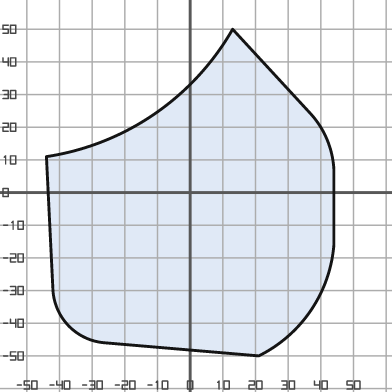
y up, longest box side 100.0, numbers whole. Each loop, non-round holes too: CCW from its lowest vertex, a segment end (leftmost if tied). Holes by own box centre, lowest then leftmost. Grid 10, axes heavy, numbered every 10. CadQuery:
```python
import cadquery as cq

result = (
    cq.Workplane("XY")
    .moveTo(21.0, -50.0)
    .threePointArc((37.0, -36.0), (44.0, -16.0))
    .lineTo(44.0, 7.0)
    .threePointArc((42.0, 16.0), (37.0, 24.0))
    .lineTo(13.0, 50.0)
    .threePointArc((-11.0, 24.0), (-44.0, 11.0))
    .lineTo(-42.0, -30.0)
    .threePointArc((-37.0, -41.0), (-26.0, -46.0))
    .close()
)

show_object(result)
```